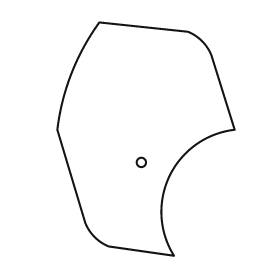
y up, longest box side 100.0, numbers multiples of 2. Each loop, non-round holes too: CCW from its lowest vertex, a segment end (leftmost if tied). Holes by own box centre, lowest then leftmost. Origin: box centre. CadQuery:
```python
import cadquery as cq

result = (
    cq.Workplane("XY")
    .moveTo(12.0, -50.0)
    .threePointArc((10.0, -16.0), (38.0, 4.0))
    .lineTo(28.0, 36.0)
    .threePointArc((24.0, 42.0), (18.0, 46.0))
    .lineTo(-20.0, 50.0)
    .threePointArc((-32.0, 28.0), (-38.0, 4.0))
    .lineTo(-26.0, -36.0)
    .threePointArc((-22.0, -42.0), (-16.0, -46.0))
    .close()
    .moveTo(-2.0, -10.0)
    .circle(2.0)
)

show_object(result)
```